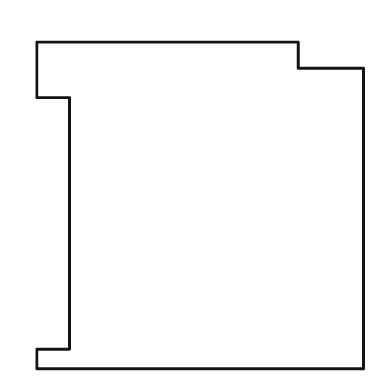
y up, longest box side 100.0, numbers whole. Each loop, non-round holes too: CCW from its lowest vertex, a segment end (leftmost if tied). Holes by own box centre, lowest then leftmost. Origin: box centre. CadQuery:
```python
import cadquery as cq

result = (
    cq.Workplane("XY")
    .moveTo(-50.0, -50.0)
    .lineTo(50.0, -50.0)
    .lineTo(50.0, 42.0)
    .lineTo(30.0, 42.0)
    .lineTo(30.0, 50.0)
    .lineTo(-50.0, 50.0)
    .lineTo(-50.0, 33.0)
    .lineTo(-40.0, 33.0)
    .lineTo(-40.0, -44.0)
    .lineTo(-50.0, -44.0)
    .close()
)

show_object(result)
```